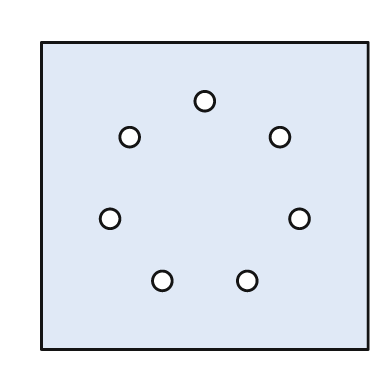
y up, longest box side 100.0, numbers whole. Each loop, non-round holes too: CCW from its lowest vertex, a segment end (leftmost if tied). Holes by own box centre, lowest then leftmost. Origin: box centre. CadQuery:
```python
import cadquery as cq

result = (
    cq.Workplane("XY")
    .moveTo(-50.0, -47.0)
    .lineTo(50.0, -47.0)
    .lineTo(50.0, 47.0)
    .lineTo(-50.0, 47.0)
    .close()
    .moveTo(-13.0, -26.0)
    .circle(3.0)
    .moveTo(13.0, -26.0)
    .circle(3.0)
    .moveTo(-29.0, -7.0)
    .circle(3.0)
    .moveTo(29.0, -7.0)
    .circle(3.0)
    .moveTo(-23.0, 18.0)
    .circle(3.0)
    .moveTo(23.0, 18.0)
    .circle(3.0)
    .moveTo(0.0, 29.0)
    .circle(3.0)
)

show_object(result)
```